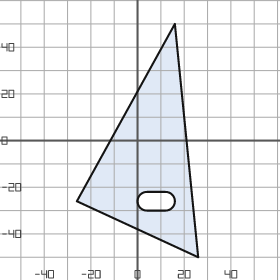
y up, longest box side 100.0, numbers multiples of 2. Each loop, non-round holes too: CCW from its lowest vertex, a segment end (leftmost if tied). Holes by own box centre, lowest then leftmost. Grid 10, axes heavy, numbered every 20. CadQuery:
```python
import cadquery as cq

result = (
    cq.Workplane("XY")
    .moveTo(26.0, -50.0)
    .lineTo(16.0, 50.0)
    .lineTo(-26.0, -26.0)
    .close()
    .moveTo(4.0, -30.0)
    .lineTo(12.0, -30.0)
    .threePointArc((16.0, -26.0), (12.0, -22.0))
    .lineTo(4.0, -22.0)
    .threePointArc((0.0, -26.0), (4.0, -30.0))
    .close()
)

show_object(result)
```